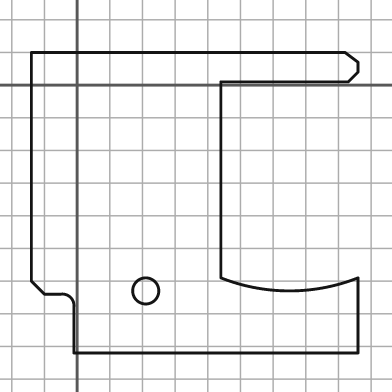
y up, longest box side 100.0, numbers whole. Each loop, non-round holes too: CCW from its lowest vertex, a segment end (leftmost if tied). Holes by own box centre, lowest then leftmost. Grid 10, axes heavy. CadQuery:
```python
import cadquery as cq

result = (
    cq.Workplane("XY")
    .moveTo(-1.0, -82.0)
    .lineTo(86.0, -82.0)
    .lineTo(86.0, -59.0)
    .threePointArc((65.0, -63.0), (44.0, -59.0))
    .lineTo(44.0, 1.0)
    .lineTo(83.0, 1.0)
    .lineTo(86.0, 4.0)
    .lineTo(86.0, 7.0)
    .lineTo(82.0, 10.0)
    .lineTo(-14.0, 10.0)
    .lineTo(-14.0, -60.0)
    .lineTo(-10.0, -64.0)
    .lineTo(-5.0, -64.0)
    .threePointArc((-2.0, -65.0), (-1.0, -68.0))
    .close()
    .moveTo(21.0, -63.0)
    .circle(4.0)
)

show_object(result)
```